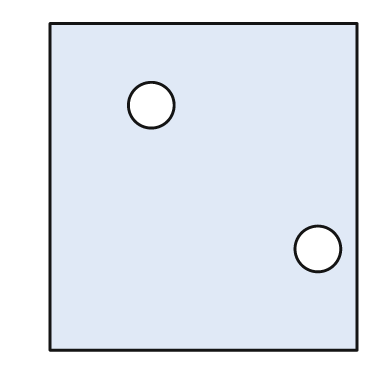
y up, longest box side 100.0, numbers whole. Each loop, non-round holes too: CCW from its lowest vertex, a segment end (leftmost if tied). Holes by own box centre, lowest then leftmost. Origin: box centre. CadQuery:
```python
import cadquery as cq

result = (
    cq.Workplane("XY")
    .moveTo(-47.0, -50.0)
    .lineTo(47.0, -50.0)
    .lineTo(47.0, 50.0)
    .lineTo(-47.0, 50.0)
    .close()
    .moveTo(35.0, -19.0)
    .circle(7.0)
    .moveTo(-16.0, 25.0)
    .circle(7.0)
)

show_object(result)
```